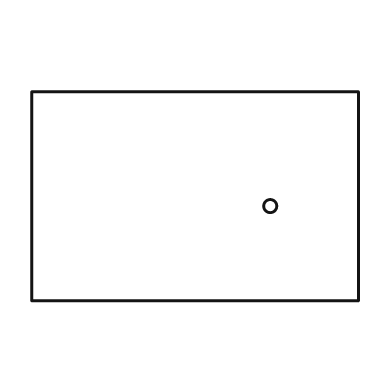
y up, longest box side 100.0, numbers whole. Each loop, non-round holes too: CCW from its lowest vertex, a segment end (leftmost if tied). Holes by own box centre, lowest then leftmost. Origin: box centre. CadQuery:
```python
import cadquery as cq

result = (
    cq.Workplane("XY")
    .moveTo(-50.0, -32.0)
    .lineTo(50.0, -32.0)
    .lineTo(50.0, 32.0)
    .lineTo(-50.0, 32.0)
    .close()
    .moveTo(23.0, -3.0)
    .circle(2.0)
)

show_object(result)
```